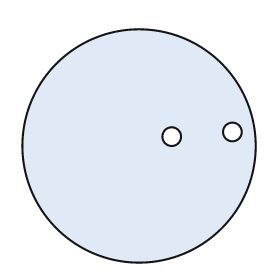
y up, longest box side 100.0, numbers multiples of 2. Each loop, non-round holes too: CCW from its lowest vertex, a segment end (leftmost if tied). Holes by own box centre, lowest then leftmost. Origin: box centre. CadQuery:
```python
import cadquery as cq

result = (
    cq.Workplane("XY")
    .moveTo(0.0, 0.0)
    .circle(50.0)
    .moveTo(14.0, 4.0)
    .circle(4.0)
    .moveTo(40.0, 6.0)
    .circle(4.0)
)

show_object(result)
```